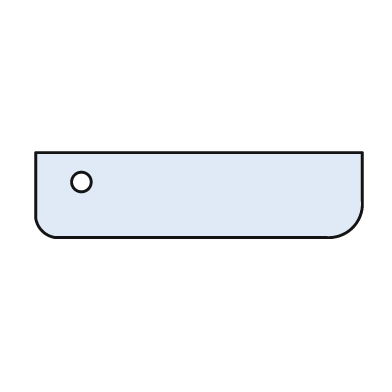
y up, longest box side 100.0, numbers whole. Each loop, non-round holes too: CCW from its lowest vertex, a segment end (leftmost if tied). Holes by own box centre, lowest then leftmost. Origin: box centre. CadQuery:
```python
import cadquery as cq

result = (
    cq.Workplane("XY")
    .moveTo(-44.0, -13.0)
    .lineTo(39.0, -13.0)
    .threePointArc((47.0, -10.0), (50.0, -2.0))
    .lineTo(50.0, 13.0)
    .lineTo(-50.0, 13.0)
    .lineTo(-50.0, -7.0)
    .threePointArc((-48.0, -11.0), (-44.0, -13.0))
    .close()
    .moveTo(-36.0, 4.0)
    .circle(3.0)
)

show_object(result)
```